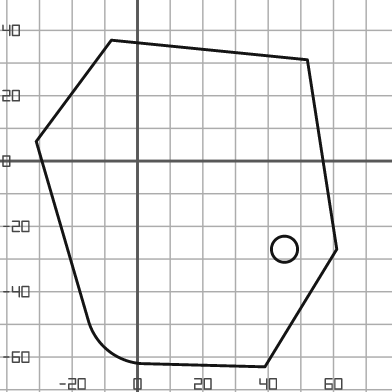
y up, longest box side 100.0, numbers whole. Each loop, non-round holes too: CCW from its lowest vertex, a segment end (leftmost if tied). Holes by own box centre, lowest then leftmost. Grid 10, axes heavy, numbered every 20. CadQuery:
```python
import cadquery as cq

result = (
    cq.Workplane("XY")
    .moveTo(39.0, -63.0)
    .lineTo(61.0, -27.0)
    .lineTo(52.0, 31.0)
    .lineTo(-8.0, 37.0)
    .lineTo(-31.0, 6.0)
    .lineTo(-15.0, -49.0)
    .threePointArc((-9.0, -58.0), (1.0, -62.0))
    .close()
    .moveTo(45.0, -27.0)
    .circle(4.0)
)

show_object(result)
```